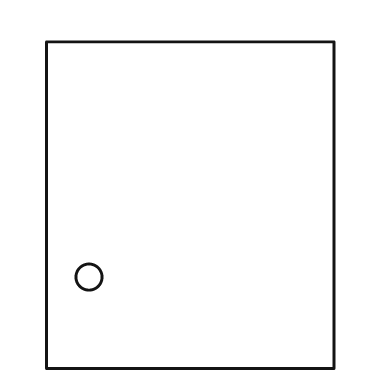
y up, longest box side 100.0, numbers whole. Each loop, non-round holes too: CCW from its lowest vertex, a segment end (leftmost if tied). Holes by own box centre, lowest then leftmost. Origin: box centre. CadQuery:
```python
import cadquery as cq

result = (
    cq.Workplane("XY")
    .moveTo(-44.0, -50.0)
    .lineTo(44.0, -50.0)
    .lineTo(44.0, 50.0)
    .lineTo(-44.0, 50.0)
    .close()
    .moveTo(-31.0, -22.0)
    .circle(4.0)
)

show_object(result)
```